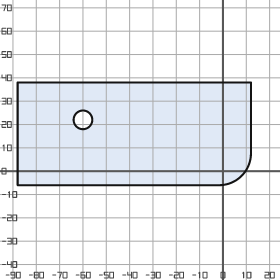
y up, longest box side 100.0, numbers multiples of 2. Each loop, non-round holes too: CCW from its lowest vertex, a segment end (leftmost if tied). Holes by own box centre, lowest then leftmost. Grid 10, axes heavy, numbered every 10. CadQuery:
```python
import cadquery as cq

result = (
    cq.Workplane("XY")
    .moveTo(-88.0, -6.0)
    .lineTo(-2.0, -6.0)
    .threePointArc((8.0, -2.0), (12.0, 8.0))
    .lineTo(12.0, 38.0)
    .lineTo(-88.0, 38.0)
    .close()
    .moveTo(-60.0, 22.0)
    .circle(4.0)
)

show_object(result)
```